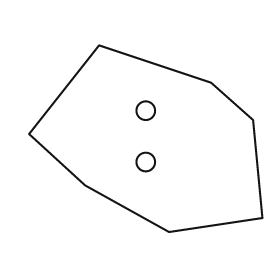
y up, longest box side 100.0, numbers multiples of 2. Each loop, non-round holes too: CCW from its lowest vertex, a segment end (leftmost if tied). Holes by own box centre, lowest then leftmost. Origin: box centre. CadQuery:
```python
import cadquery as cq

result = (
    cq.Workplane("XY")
    .moveTo(10.0, -40.0)
    .lineTo(50.0, -34.0)
    .lineTo(46.0, 8.0)
    .lineTo(28.0, 24.0)
    .lineTo(-20.0, 40.0)
    .lineTo(-50.0, 2.0)
    .lineTo(-26.0, -20.0)
    .close()
    .moveTo(0.0, -10.0)
    .circle(4.0)
    .moveTo(0.0, 12.0)
    .circle(4.0)
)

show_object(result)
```